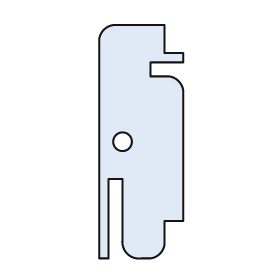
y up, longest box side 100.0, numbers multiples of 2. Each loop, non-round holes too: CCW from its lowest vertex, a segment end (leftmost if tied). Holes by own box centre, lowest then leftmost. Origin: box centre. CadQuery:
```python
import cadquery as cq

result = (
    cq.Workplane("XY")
    .moveTo(-18.0, -50.0)
    .lineTo(-14.0, -50.0)
    .lineTo(-14.0, -16.0)
    .lineTo(-8.0, -16.0)
    .lineTo(-8.0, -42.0)
    .threePointArc((-6.0, -48.0), (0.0, -50.0))
    .lineTo(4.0, -50.0)
    .threePointArc((8.0, -48.0), (10.0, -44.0))
    .lineTo(10.0, -34.0)
    .lineTo(18.0, -34.0)
    .lineTo(18.0, 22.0)
    .threePointArc((16.0, 26.0), (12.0, 28.0))
    .lineTo(4.0, 28.0)
    .lineTo(4.0, 34.0)
    .lineTo(18.0, 34.0)
    .lineTo(18.0, 38.0)
    .lineTo(10.0, 38.0)
    .lineTo(10.0, 50.0)
    .lineTo(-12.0, 50.0)
    .threePointArc((-16.0, 48.0), (-18.0, 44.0))
    .close()
    .moveTo(-8.0, 0.0)
    .circle(4.0)
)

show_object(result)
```